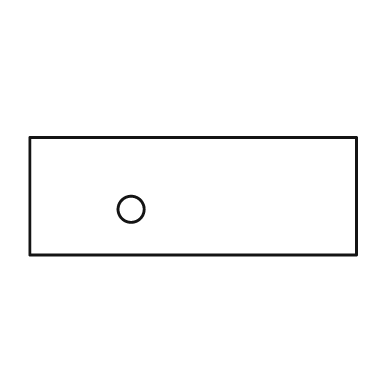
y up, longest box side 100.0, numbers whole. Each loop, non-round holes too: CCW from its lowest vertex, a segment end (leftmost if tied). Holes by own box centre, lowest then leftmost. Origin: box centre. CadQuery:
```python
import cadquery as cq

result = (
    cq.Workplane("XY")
    .moveTo(-50.0, -18.0)
    .lineTo(50.0, -18.0)
    .lineTo(50.0, 18.0)
    .lineTo(-50.0, 18.0)
    .close()
    .moveTo(-19.0, -4.0)
    .circle(4.0)
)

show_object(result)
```